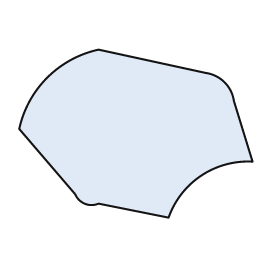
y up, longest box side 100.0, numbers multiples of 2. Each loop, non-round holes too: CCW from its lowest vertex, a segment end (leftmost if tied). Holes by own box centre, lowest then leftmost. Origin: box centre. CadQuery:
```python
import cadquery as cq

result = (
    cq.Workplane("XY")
    .moveTo(14.0, -36.0)
    .threePointArc((28.0, -18.0), (50.0, -12.0))
    .lineTo(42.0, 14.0)
    .threePointArc((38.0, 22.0), (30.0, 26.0))
    .lineTo(-16.0, 36.0)
    .threePointArc((-38.0, 24.0), (-50.0, 2.0))
    .lineTo(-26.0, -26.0)
    .threePointArc((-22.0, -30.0), (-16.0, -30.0))
    .close()
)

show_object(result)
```